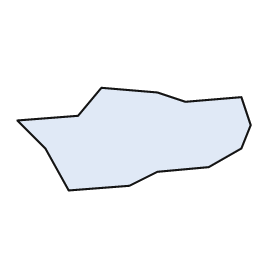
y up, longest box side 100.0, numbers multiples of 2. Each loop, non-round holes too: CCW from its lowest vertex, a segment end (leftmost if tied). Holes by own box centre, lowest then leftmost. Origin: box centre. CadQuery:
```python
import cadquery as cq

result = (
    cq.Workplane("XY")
    .moveTo(-28.0, -22.0)
    .lineTo(-2.0, -20.0)
    .lineTo(10.0, -14.0)
    .lineTo(32.0, -12.0)
    .lineTo(46.0, -4.0)
    .lineTo(50.0, 6.0)
    .lineTo(46.0, 18.0)
    .lineTo(22.0, 16.0)
    .lineTo(10.0, 20.0)
    .lineTo(-14.0, 22.0)
    .lineTo(-24.0, 10.0)
    .lineTo(-50.0, 8.0)
    .lineTo(-38.0, -4.0)
    .close()
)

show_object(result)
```